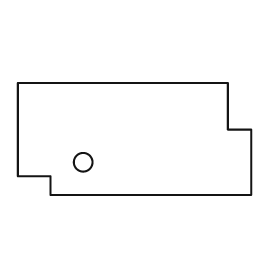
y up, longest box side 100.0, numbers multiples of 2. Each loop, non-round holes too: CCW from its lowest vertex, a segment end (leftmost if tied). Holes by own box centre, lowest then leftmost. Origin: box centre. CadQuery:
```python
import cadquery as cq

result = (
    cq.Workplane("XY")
    .moveTo(-36.0, -24.0)
    .lineTo(50.0, -24.0)
    .lineTo(50.0, 4.0)
    .lineTo(40.0, 4.0)
    .lineTo(40.0, 24.0)
    .lineTo(-50.0, 24.0)
    .lineTo(-50.0, -16.0)
    .lineTo(-36.0, -16.0)
    .close()
    .moveTo(-22.0, -10.0)
    .circle(4.0)
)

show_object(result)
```